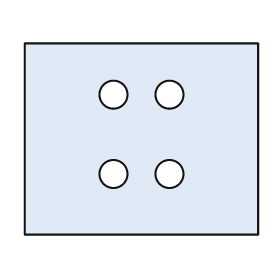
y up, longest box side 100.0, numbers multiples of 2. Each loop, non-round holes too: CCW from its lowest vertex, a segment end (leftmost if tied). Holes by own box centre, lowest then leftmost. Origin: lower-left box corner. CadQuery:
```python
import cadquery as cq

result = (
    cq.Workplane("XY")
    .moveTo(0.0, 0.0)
    .lineTo(100.0, 0.0)
    .lineTo(100.0, 82.0)
    .lineTo(0.0, 82.0)
    .close()
    .moveTo(38.0, 26.0)
    .circle(6.0)
    .moveTo(62.0, 26.0)
    .circle(6.0)
    .moveTo(38.0, 60.0)
    .circle(6.0)
    .moveTo(62.0, 60.0)
    .circle(6.0)
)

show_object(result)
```